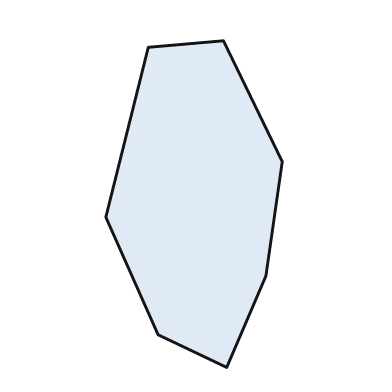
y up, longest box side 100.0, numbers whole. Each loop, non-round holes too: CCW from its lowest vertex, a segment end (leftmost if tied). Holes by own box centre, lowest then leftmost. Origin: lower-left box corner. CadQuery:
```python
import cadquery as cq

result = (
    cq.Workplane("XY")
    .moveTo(37.0, 0.0)
    .lineTo(49.0, 28.0)
    .lineTo(54.0, 63.0)
    .lineTo(36.0, 100.0)
    .lineTo(13.0, 98.0)
    .lineTo(0.0, 46.0)
    .lineTo(16.0, 10.0)
    .close()
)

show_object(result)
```